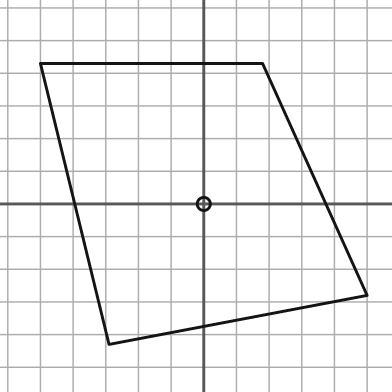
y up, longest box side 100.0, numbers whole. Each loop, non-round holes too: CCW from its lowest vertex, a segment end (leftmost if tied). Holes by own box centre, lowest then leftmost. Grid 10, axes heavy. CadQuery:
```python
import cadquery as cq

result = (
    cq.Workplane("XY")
    .moveTo(-29.0, -43.0)
    .lineTo(50.0, -28.0)
    .lineTo(18.0, 43.0)
    .lineTo(-50.0, 43.0)
    .close()
    .moveTo(0.0, 0.0)
    .circle(2.0)
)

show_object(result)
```